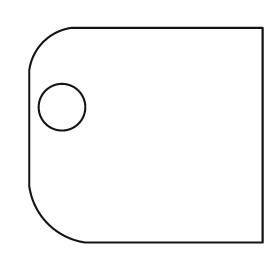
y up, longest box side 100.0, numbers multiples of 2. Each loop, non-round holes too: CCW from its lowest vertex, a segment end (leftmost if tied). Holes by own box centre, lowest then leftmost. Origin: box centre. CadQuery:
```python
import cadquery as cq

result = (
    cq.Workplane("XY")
    .moveTo(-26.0, -46.0)
    .lineTo(50.0, -46.0)
    .lineTo(50.0, 46.0)
    .lineTo(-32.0, 46.0)
    .threePointArc((-44.0, 40.0), (-50.0, 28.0))
    .lineTo(-50.0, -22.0)
    .threePointArc((-42.0, -38.0), (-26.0, -46.0))
    .close()
    .moveTo(-36.0, 12.0)
    .circle(10.0)
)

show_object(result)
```